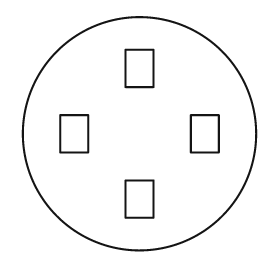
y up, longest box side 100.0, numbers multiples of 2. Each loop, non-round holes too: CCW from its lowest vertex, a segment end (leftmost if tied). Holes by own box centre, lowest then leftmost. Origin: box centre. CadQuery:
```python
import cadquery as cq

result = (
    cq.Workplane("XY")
    .moveTo(0.0, 0.0)
    .circle(50.0)
    .moveTo(-6.0, -36.0)
    .lineTo(6.0, -36.0)
    .lineTo(6.0, -20.0)
    .lineTo(-6.0, -20.0)
    .close()
    .moveTo(-34.0, -8.0)
    .lineTo(-22.0, -8.0)
    .lineTo(-22.0, 8.0)
    .lineTo(-34.0, 8.0)
    .close()
    .moveTo(22.0, -8.0)
    .lineTo(34.0, -8.0)
    .lineTo(34.0, 8.0)
    .lineTo(22.0, 8.0)
    .close()
    .moveTo(-6.0, 20.0)
    .lineTo(6.0, 20.0)
    .lineTo(6.0, 36.0)
    .lineTo(-6.0, 36.0)
    .close()
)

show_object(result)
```